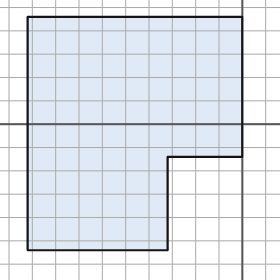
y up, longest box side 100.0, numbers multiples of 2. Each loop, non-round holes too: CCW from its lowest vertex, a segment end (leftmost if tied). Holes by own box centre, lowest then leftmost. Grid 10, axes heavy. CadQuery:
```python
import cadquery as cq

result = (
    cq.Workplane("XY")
    .moveTo(-92.0, -54.0)
    .lineTo(-32.0, -54.0)
    .lineTo(-32.0, -14.0)
    .lineTo(0.0, -14.0)
    .lineTo(0.0, 46.0)
    .lineTo(-92.0, 46.0)
    .close()
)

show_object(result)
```